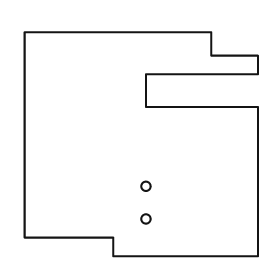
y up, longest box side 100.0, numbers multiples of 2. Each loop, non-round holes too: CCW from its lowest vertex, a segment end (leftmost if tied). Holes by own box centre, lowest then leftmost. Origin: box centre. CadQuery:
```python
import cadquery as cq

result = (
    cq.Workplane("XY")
    .moveTo(-12.0, -48.0)
    .lineTo(50.0, -48.0)
    .lineTo(50.0, 16.0)
    .lineTo(2.0, 16.0)
    .lineTo(2.0, 30.0)
    .lineTo(50.0, 30.0)
    .lineTo(50.0, 38.0)
    .lineTo(30.0, 38.0)
    .lineTo(30.0, 48.0)
    .lineTo(-50.0, 48.0)
    .lineTo(-50.0, -40.0)
    .lineTo(-12.0, -40.0)
    .close()
    .moveTo(2.0, -32.0)
    .circle(2.0)
    .moveTo(2.0, -18.0)
    .circle(2.0)
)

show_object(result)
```